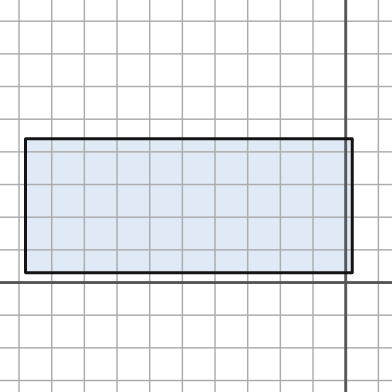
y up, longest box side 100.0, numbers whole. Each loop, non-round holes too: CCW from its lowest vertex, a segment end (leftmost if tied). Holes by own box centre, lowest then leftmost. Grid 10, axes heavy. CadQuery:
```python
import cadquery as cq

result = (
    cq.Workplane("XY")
    .moveTo(-98.0, 3.0)
    .lineTo(2.0, 3.0)
    .lineTo(2.0, 44.0)
    .lineTo(-98.0, 44.0)
    .close()
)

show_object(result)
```